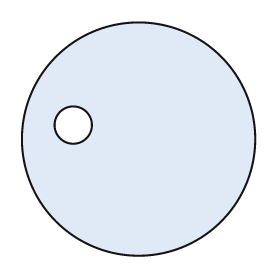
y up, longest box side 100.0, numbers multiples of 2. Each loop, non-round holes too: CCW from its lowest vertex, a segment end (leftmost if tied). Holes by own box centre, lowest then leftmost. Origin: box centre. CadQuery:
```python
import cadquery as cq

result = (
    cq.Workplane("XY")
    .moveTo(0.0, 0.0)
    .circle(50.0)
    .moveTo(-28.0, 6.0)
    .circle(8.0)
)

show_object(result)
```